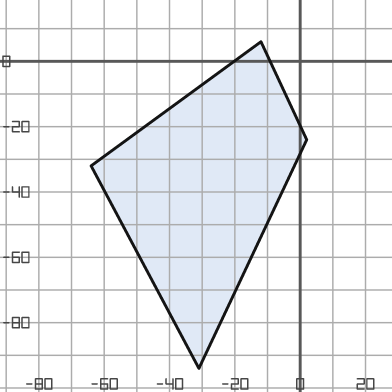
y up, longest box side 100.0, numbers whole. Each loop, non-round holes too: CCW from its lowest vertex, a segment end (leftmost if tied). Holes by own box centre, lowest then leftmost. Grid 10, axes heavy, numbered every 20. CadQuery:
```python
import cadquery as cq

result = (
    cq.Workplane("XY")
    .moveTo(-31.0, -94.0)
    .lineTo(2.0, -24.0)
    .lineTo(-12.0, 6.0)
    .lineTo(-64.0, -32.0)
    .close()
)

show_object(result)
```